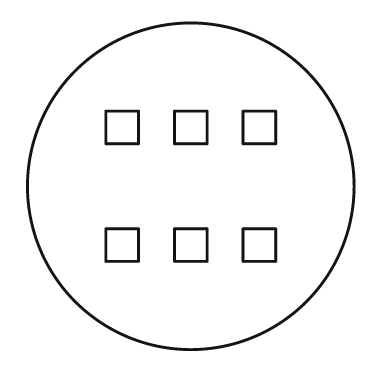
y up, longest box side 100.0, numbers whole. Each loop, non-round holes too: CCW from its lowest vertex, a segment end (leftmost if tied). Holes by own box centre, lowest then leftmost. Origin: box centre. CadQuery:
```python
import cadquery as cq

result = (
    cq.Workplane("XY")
    .moveTo(0.0, 0.0)
    .circle(50.0)
    .moveTo(-26.0, -23.0)
    .lineTo(-16.0, -23.0)
    .lineTo(-16.0, -13.0)
    .lineTo(-26.0, -13.0)
    .close()
    .moveTo(-5.0, -23.0)
    .lineTo(5.0, -23.0)
    .lineTo(5.0, -13.0)
    .lineTo(-5.0, -13.0)
    .close()
    .moveTo(16.0, -23.0)
    .lineTo(26.0, -23.0)
    .lineTo(26.0, -13.0)
    .lineTo(16.0, -13.0)
    .close()
    .moveTo(-26.0, 13.0)
    .lineTo(-16.0, 13.0)
    .lineTo(-16.0, 23.0)
    .lineTo(-26.0, 23.0)
    .close()
    .moveTo(-5.0, 13.0)
    .lineTo(5.0, 13.0)
    .lineTo(5.0, 23.0)
    .lineTo(-5.0, 23.0)
    .close()
    .moveTo(16.0, 13.0)
    .lineTo(26.0, 13.0)
    .lineTo(26.0, 23.0)
    .lineTo(16.0, 23.0)
    .close()
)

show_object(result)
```